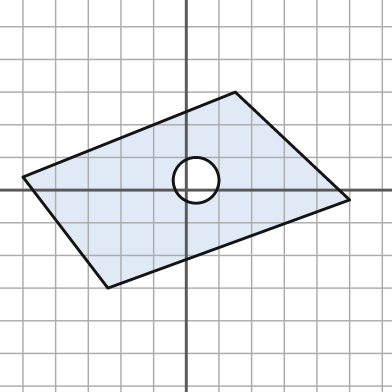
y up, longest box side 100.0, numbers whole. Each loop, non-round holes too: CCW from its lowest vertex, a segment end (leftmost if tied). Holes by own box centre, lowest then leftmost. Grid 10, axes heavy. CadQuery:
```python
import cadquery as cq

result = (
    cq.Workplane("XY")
    .moveTo(-24.0, -30.0)
    .lineTo(50.0, -3.0)
    .lineTo(15.0, 30.0)
    .lineTo(-50.0, 4.0)
    .close()
    .moveTo(3.0, 3.0)
    .circle(7.0)
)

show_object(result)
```